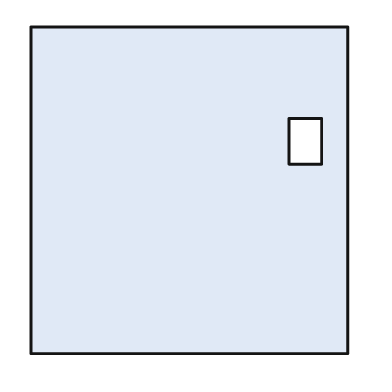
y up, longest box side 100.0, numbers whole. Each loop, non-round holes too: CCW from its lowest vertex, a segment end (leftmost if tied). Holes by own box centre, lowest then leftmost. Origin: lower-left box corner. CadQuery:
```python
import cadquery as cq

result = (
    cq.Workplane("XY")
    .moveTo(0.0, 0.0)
    .lineTo(97.0, 0.0)
    .lineTo(97.0, 100.0)
    .lineTo(0.0, 100.0)
    .close()
    .moveTo(79.0, 58.0)
    .lineTo(89.0, 58.0)
    .lineTo(89.0, 72.0)
    .lineTo(79.0, 72.0)
    .close()
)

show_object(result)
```